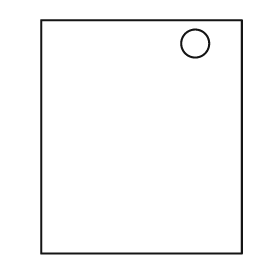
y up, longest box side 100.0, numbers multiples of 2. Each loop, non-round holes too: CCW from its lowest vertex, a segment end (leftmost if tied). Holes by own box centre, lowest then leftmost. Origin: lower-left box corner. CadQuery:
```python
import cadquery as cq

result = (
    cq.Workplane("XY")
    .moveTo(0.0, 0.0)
    .lineTo(86.0, 0.0)
    .lineTo(86.0, 100.0)
    .lineTo(0.0, 100.0)
    .close()
    .moveTo(66.0, 90.0)
    .circle(6.0)
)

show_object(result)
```